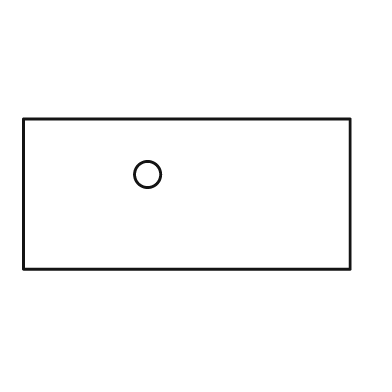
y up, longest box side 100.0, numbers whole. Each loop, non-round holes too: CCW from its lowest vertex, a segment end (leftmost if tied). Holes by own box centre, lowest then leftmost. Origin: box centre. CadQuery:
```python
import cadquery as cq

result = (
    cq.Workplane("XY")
    .moveTo(-50.0, -23.0)
    .lineTo(50.0, -23.0)
    .lineTo(50.0, 23.0)
    .lineTo(-50.0, 23.0)
    .close()
    .moveTo(-12.0, 6.0)
    .circle(4.0)
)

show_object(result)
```